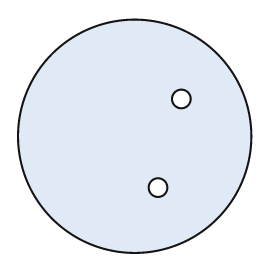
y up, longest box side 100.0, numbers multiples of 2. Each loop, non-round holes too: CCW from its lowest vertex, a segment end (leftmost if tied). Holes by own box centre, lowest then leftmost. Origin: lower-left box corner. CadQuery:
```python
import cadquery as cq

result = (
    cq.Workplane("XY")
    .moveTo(50.0, 50.0)
    .circle(50.0)
    .moveTo(60.0, 28.0)
    .circle(4.0)
    .moveTo(70.0, 66.0)
    .circle(4.0)
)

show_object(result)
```